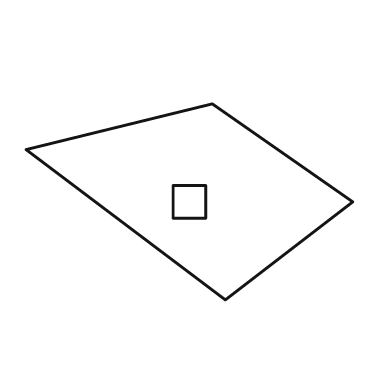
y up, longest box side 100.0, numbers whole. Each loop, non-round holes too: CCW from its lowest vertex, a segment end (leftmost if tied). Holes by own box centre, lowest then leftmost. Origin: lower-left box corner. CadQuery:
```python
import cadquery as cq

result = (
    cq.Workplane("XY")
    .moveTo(61.0, 0.0)
    .lineTo(100.0, 30.0)
    .lineTo(57.0, 60.0)
    .lineTo(0.0, 46.0)
    .close()
    .moveTo(45.0, 25.0)
    .lineTo(55.0, 25.0)
    .lineTo(55.0, 35.0)
    .lineTo(45.0, 35.0)
    .close()
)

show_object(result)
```